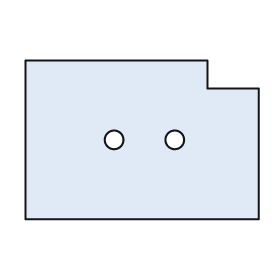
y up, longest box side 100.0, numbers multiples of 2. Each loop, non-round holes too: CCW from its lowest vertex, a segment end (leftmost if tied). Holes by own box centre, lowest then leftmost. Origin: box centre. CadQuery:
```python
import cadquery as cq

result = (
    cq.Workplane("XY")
    .moveTo(-50.0, -34.0)
    .lineTo(50.0, -34.0)
    .lineTo(50.0, 22.0)
    .lineTo(28.0, 22.0)
    .lineTo(28.0, 34.0)
    .lineTo(-50.0, 34.0)
    .close()
    .moveTo(-12.0, 0.0)
    .circle(4.0)
    .moveTo(14.0, 0.0)
    .circle(4.0)
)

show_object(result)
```